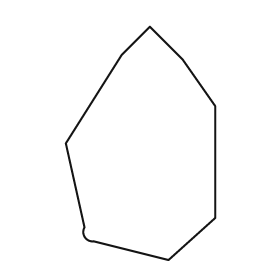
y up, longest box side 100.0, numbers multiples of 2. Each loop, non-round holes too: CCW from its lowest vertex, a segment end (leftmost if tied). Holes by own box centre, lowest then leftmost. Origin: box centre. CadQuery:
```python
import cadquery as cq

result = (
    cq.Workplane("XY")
    .moveTo(12.0, -50.0)
    .lineTo(32.0, -32.0)
    .lineTo(32.0, 16.0)
    .lineTo(18.0, 36.0)
    .lineTo(4.0, 50.0)
    .lineTo(-8.0, 38.0)
    .lineTo(-32.0, 0.0)
    .lineTo(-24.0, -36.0)
    .threePointArc((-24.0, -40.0), (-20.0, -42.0))
    .close()
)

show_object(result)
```